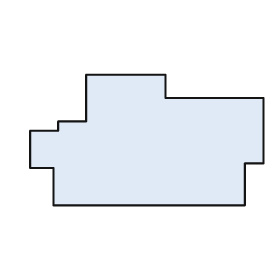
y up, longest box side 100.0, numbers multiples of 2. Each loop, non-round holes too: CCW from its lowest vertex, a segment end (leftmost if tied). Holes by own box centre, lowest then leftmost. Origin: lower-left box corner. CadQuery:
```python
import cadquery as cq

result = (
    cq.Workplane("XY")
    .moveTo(10.0, 0.0)
    .lineTo(92.0, 0.0)
    .lineTo(92.0, 18.0)
    .lineTo(100.0, 18.0)
    .lineTo(100.0, 46.0)
    .lineTo(58.0, 46.0)
    .lineTo(58.0, 56.0)
    .lineTo(24.0, 56.0)
    .lineTo(24.0, 36.0)
    .lineTo(12.0, 36.0)
    .lineTo(12.0, 32.0)
    .lineTo(0.0, 32.0)
    .lineTo(0.0, 16.0)
    .lineTo(10.0, 16.0)
    .close()
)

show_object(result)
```